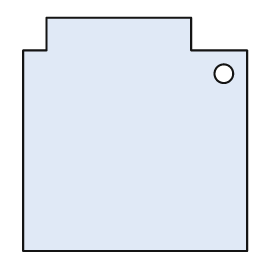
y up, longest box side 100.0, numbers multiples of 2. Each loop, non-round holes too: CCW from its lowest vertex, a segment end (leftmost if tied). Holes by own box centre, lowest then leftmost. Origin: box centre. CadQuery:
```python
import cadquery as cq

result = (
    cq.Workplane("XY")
    .moveTo(-48.0, -50.0)
    .lineTo(48.0, -50.0)
    .lineTo(48.0, 36.0)
    .lineTo(24.0, 36.0)
    .lineTo(24.0, 50.0)
    .lineTo(-38.0, 50.0)
    .lineTo(-38.0, 36.0)
    .lineTo(-48.0, 36.0)
    .close()
    .moveTo(38.0, 26.0)
    .circle(4.0)
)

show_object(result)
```